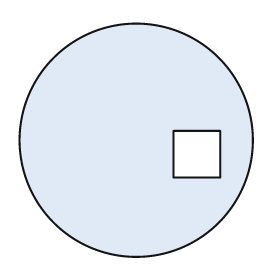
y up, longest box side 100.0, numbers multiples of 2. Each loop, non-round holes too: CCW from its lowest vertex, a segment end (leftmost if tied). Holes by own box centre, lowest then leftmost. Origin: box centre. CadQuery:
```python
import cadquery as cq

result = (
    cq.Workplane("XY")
    .moveTo(0.0, 0.0)
    .circle(50.0)
    .moveTo(16.0, -16.0)
    .lineTo(36.0, -16.0)
    .lineTo(36.0, 4.0)
    .lineTo(16.0, 4.0)
    .close()
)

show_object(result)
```